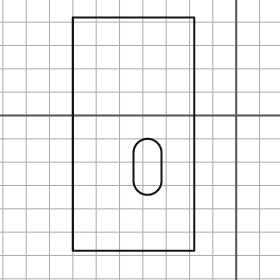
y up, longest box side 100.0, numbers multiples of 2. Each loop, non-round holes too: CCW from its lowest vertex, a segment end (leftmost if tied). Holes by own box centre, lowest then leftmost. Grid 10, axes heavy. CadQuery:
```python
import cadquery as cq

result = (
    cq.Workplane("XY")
    .moveTo(-70.0, -58.0)
    .lineTo(-18.0, -58.0)
    .lineTo(-18.0, 42.0)
    .lineTo(-70.0, 42.0)
    .close()
    .moveTo(-44.0, -28.0)
    .threePointArc((-38.0, -34.0), (-32.0, -28.0))
    .lineTo(-32.0, -16.0)
    .threePointArc((-38.0, -10.0), (-44.0, -16.0))
    .close()
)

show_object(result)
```